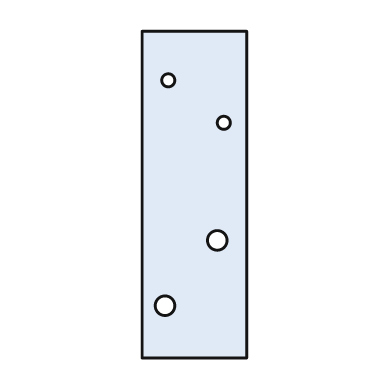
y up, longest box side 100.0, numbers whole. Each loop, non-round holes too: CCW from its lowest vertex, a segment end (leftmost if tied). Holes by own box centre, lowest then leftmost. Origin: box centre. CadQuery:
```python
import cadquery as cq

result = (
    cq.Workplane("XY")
    .moveTo(-16.0, -50.0)
    .lineTo(16.0, -50.0)
    .lineTo(16.0, 50.0)
    .lineTo(-16.0, 50.0)
    .close()
    .moveTo(-9.0, -34.0)
    .circle(3.0)
    .moveTo(7.0, -14.0)
    .circle(3.0)
    .moveTo(9.0, 22.0)
    .circle(2.0)
    .moveTo(-8.0, 35.0)
    .circle(2.0)
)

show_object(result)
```